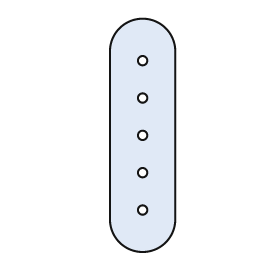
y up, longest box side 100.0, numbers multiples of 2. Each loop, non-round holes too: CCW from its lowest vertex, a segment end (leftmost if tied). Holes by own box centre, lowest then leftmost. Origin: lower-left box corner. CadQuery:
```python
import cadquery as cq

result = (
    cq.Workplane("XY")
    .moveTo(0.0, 14.0)
    .threePointArc((14.0, 0.0), (28.0, 14.0))
    .lineTo(28.0, 86.0)
    .threePointArc((14.0, 100.0), (0.0, 86.0))
    .close()
    .moveTo(14.0, 18.0)
    .circle(2.0)
    .moveTo(14.0, 34.0)
    .circle(2.0)
    .moveTo(14.0, 50.0)
    .circle(2.0)
    .moveTo(14.0, 66.0)
    .circle(2.0)
    .moveTo(14.0, 82.0)
    .circle(2.0)
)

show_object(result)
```